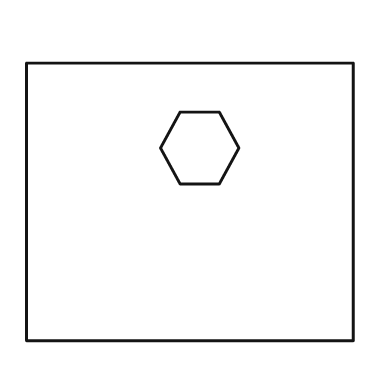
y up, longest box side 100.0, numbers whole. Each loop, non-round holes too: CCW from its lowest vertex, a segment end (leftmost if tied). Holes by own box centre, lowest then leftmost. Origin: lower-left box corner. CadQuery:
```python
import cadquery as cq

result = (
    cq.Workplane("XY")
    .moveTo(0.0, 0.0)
    .lineTo(100.0, 0.0)
    .lineTo(100.0, 85.0)
    .lineTo(0.0, 85.0)
    .close()
    .moveTo(47.0, 48.0)
    .lineTo(59.0, 48.0)
    .lineTo(65.0, 59.0)
    .lineTo(59.0, 70.0)
    .lineTo(47.0, 70.0)
    .lineTo(41.0, 59.0)
    .close()
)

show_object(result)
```